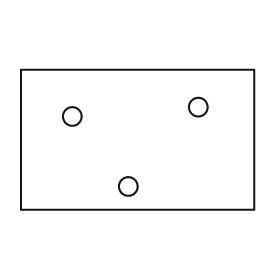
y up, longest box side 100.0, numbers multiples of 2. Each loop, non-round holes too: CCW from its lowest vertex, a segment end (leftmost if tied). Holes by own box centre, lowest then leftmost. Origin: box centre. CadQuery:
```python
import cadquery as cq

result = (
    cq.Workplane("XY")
    .moveTo(-50.0, -30.0)
    .lineTo(50.0, -30.0)
    .lineTo(50.0, 30.0)
    .lineTo(-50.0, 30.0)
    .close()
    .moveTo(-4.0, -20.0)
    .circle(4.0)
    .moveTo(-28.0, 10.0)
    .circle(4.0)
    .moveTo(26.0, 14.0)
    .circle(4.0)
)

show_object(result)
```